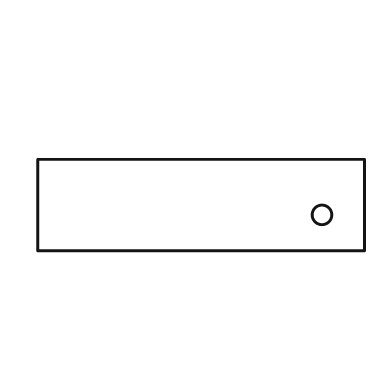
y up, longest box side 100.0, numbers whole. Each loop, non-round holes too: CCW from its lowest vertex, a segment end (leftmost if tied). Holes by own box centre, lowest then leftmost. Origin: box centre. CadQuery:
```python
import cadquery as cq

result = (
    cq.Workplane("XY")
    .moveTo(-50.0, -14.0)
    .lineTo(50.0, -14.0)
    .lineTo(50.0, 14.0)
    .lineTo(-50.0, 14.0)
    .close()
    .moveTo(37.0, -3.0)
    .circle(3.0)
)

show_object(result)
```